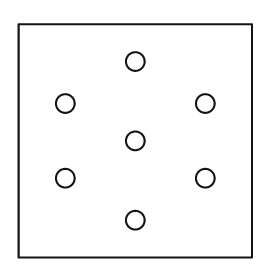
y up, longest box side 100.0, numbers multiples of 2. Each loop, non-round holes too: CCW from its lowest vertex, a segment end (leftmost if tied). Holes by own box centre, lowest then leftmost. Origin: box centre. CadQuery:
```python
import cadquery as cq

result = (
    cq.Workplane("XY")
    .moveTo(-50.0, -50.0)
    .lineTo(50.0, -50.0)
    .lineTo(50.0, 50.0)
    .lineTo(-50.0, 50.0)
    .close()
    .moveTo(0.0, -34.0)
    .circle(4.0)
    .moveTo(-30.0, -16.0)
    .circle(4.0)
    .moveTo(30.0, -16.0)
    .circle(4.0)
    .moveTo(0.0, 0.0)
    .circle(4.0)
    .moveTo(-30.0, 16.0)
    .circle(4.0)
    .moveTo(30.0, 16.0)
    .circle(4.0)
    .moveTo(0.0, 34.0)
    .circle(4.0)
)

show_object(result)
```